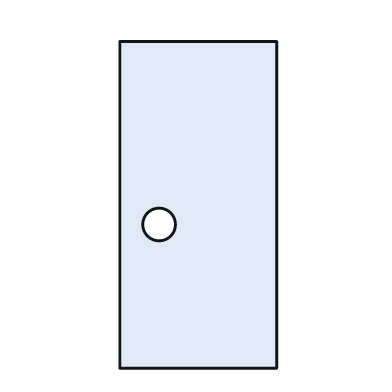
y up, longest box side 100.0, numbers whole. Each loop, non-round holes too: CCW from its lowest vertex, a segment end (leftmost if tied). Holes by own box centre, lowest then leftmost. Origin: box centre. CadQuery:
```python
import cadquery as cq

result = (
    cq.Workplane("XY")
    .moveTo(-24.0, -50.0)
    .lineTo(24.0, -50.0)
    .lineTo(24.0, 50.0)
    .lineTo(-24.0, 50.0)
    .close()
    .moveTo(-12.0, -6.0)
    .circle(5.0)
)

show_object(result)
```